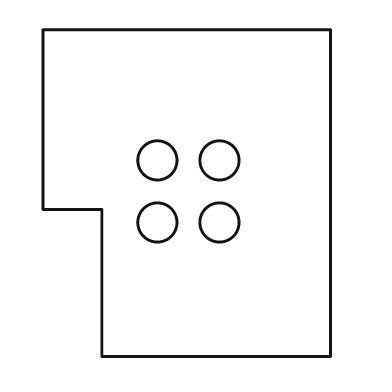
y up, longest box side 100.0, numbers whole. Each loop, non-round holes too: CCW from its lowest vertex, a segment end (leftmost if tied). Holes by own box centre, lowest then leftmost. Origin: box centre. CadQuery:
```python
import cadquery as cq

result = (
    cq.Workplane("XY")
    .moveTo(-26.0, -50.0)
    .lineTo(44.0, -50.0)
    .lineTo(44.0, 50.0)
    .lineTo(-44.0, 50.0)
    .lineTo(-44.0, -5.0)
    .lineTo(-26.0, -5.0)
    .close()
    .moveTo(-9.0, -9.0)
    .circle(6.0)
    .moveTo(10.0, -9.0)
    .circle(6.0)
    .moveTo(-9.0, 10.0)
    .circle(6.0)
    .moveTo(10.0, 10.0)
    .circle(6.0)
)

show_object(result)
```